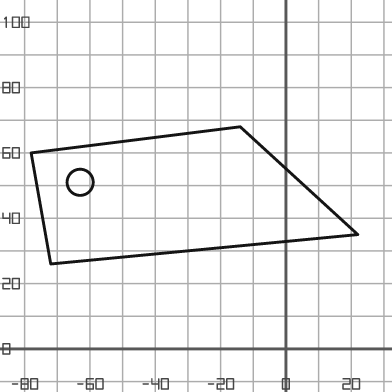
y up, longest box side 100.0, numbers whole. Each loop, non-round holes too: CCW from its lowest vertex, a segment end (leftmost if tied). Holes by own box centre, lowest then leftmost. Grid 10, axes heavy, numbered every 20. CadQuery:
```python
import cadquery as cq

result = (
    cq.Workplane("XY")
    .moveTo(-72.0, 26.0)
    .lineTo(22.0, 35.0)
    .lineTo(-14.0, 68.0)
    .lineTo(-78.0, 60.0)
    .close()
    .moveTo(-63.0, 51.0)
    .circle(4.0)
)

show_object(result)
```